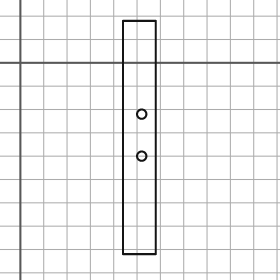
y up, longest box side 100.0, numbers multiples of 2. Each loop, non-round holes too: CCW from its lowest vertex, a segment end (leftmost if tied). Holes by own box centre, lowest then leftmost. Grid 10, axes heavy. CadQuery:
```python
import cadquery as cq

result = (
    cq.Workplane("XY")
    .moveTo(44.0, -82.0)
    .lineTo(58.0, -82.0)
    .lineTo(58.0, 18.0)
    .lineTo(44.0, 18.0)
    .close()
    .moveTo(52.0, -40.0)
    .circle(2.0)
    .moveTo(52.0, -22.0)
    .circle(2.0)
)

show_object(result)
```